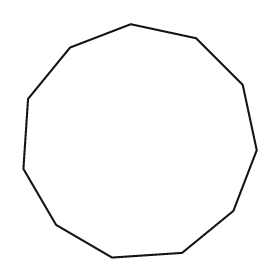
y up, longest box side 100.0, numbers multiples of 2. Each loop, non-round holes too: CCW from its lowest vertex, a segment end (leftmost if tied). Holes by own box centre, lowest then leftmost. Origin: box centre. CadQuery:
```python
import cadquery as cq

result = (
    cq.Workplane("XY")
    .moveTo(-12.0, -50.0)
    .lineTo(18.0, -48.0)
    .lineTo(40.0, -30.0)
    .lineTo(50.0, -4.0)
    .lineTo(44.0, 24.0)
    .lineTo(24.0, 44.0)
    .lineTo(-4.0, 50.0)
    .lineTo(-30.0, 40.0)
    .lineTo(-48.0, 18.0)
    .lineTo(-50.0, -12.0)
    .lineTo(-36.0, -36.0)
    .close()
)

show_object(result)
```